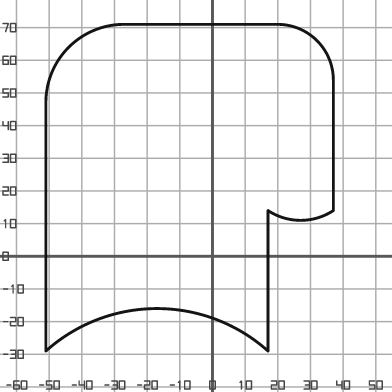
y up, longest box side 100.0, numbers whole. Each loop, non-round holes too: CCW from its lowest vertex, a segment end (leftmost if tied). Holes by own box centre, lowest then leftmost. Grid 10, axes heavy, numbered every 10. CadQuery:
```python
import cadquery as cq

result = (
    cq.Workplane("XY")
    .moveTo(-51.0, -29.0)
    .threePointArc((-17.0, -16.0), (17.0, -29.0))
    .lineTo(17.0, 14.0)
    .threePointArc((27.0, 11.0), (37.0, 14.0))
    .lineTo(37.0, 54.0)
    .threePointArc((32.0, 66.0), (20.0, 71.0))
    .lineTo(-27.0, 71.0)
    .threePointArc((-44.0, 64.0), (-51.0, 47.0))
    .close()
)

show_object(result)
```